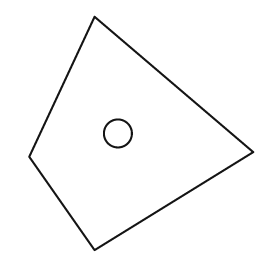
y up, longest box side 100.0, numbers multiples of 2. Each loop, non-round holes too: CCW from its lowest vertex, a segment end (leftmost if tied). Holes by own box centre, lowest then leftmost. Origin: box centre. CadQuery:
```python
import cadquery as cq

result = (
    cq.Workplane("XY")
    .moveTo(-20.0, -50.0)
    .lineTo(48.0, -8.0)
    .lineTo(-20.0, 50.0)
    .lineTo(-48.0, -10.0)
    .close()
    .moveTo(-10.0, 0.0)
    .circle(6.0)
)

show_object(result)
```